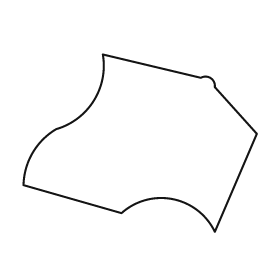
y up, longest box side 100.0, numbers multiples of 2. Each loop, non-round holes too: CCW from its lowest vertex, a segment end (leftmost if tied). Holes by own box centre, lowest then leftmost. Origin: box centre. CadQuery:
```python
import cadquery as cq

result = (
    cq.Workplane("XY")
    .moveTo(32.0, -38.0)
    .lineTo(50.0, 4.0)
    .lineTo(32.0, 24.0)
    .threePointArc((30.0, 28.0), (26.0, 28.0))
    .lineTo(-16.0, 38.0)
    .threePointArc((-20.0, 18.0), (-36.0, 6.0))
    .threePointArc((-46.0, -4.0), (-50.0, -18.0))
    .lineTo(-8.0, -30.0)
    .threePointArc((14.0, -24.0), (32.0, -38.0))
    .close()
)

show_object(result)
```